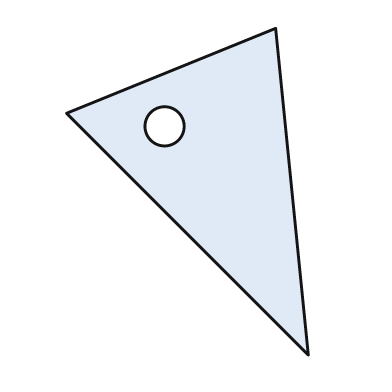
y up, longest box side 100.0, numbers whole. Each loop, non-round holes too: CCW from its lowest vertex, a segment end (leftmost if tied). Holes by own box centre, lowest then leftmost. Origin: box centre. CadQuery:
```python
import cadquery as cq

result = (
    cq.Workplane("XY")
    .moveTo(37.0, -50.0)
    .lineTo(27.0, 50.0)
    .lineTo(-37.0, 24.0)
    .close()
    .moveTo(-7.0, 20.0)
    .circle(6.0)
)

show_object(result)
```